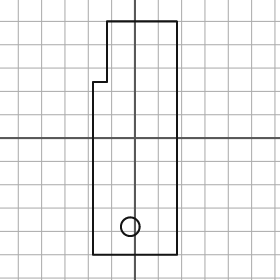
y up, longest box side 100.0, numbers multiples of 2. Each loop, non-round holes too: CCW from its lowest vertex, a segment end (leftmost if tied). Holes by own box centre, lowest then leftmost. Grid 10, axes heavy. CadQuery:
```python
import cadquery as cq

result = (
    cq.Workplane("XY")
    .moveTo(-18.0, -50.0)
    .lineTo(18.0, -50.0)
    .lineTo(18.0, 50.0)
    .lineTo(-12.0, 50.0)
    .lineTo(-12.0, 24.0)
    .lineTo(-18.0, 24.0)
    .close()
    .moveTo(-2.0, -38.0)
    .circle(4.0)
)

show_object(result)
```